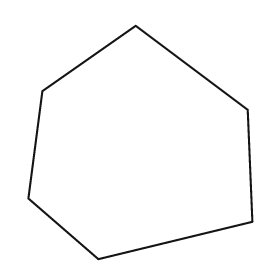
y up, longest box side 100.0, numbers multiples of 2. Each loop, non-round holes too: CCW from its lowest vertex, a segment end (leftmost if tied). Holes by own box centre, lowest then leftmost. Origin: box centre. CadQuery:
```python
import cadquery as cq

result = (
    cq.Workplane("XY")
    .moveTo(-18.0, -50.0)
    .lineTo(48.0, -34.0)
    .lineTo(46.0, 14.0)
    .lineTo(-2.0, 50.0)
    .lineTo(-42.0, 22.0)
    .lineTo(-48.0, -24.0)
    .close()
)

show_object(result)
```